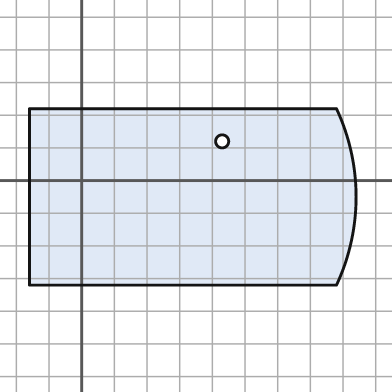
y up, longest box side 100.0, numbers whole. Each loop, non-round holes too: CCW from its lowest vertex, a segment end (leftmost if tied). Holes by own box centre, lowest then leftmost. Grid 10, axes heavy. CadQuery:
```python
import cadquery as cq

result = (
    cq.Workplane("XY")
    .moveTo(-16.0, -32.0)
    .lineTo(78.0, -32.0)
    .threePointArc((84.0, -5.0), (78.0, 22.0))
    .lineTo(-16.0, 22.0)
    .close()
    .moveTo(43.0, 12.0)
    .circle(2.0)
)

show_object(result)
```